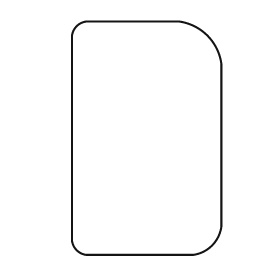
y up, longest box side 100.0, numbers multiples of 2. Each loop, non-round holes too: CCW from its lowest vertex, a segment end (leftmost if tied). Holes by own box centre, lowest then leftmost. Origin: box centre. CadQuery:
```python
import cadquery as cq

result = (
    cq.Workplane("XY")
    .moveTo(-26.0, -50.0)
    .lineTo(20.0, -50.0)
    .threePointArc((28.0, -46.0), (32.0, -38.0))
    .lineTo(32.0, 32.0)
    .threePointArc((26.0, 44.0), (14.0, 50.0))
    .lineTo(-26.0, 50.0)
    .threePointArc((-30.0, 48.0), (-32.0, 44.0))
    .lineTo(-32.0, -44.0)
    .threePointArc((-30.0, -48.0), (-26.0, -50.0))
    .close()
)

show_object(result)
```